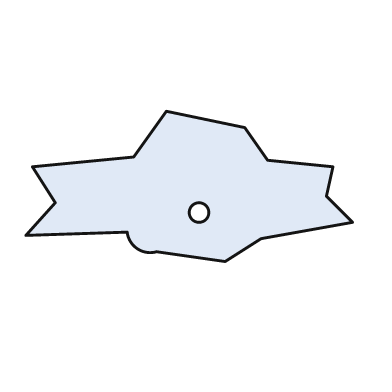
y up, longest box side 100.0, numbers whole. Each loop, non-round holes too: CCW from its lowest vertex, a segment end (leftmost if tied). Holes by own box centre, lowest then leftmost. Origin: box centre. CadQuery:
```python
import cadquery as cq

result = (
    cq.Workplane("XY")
    .moveTo(11.0, -23.0)
    .lineTo(22.0, -16.0)
    .lineTo(50.0, -11.0)
    .lineTo(42.0, -3.0)
    .lineTo(44.0, 6.0)
    .lineTo(24.0, 8.0)
    .lineTo(17.0, 18.0)
    .lineTo(-7.0, 23.0)
    .lineTo(-17.0, 9.0)
    .lineTo(-48.0, 6.0)
    .lineTo(-41.0, -5.0)
    .lineTo(-50.0, -15.0)
    .lineTo(-19.0, -14.0)
    .threePointArc((-16.0, -19.0), (-10.0, -20.0))
    .close()
    .moveTo(3.0, -8.0)
    .circle(3.0)
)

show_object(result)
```